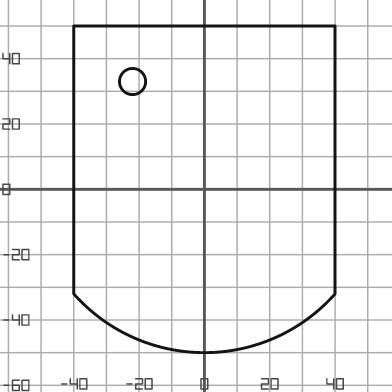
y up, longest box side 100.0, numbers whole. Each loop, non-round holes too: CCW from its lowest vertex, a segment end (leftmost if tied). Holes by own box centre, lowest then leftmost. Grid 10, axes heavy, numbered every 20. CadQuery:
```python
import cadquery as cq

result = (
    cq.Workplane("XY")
    .moveTo(-40.0, -32.0)
    .threePointArc((0.0, -50.0), (40.0, -32.0))
    .lineTo(40.0, 50.0)
    .lineTo(-40.0, 50.0)
    .close()
    .moveTo(-22.0, 33.0)
    .circle(4.0)
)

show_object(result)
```